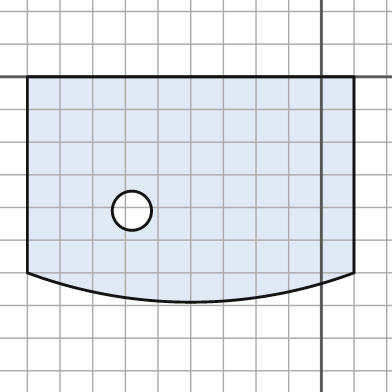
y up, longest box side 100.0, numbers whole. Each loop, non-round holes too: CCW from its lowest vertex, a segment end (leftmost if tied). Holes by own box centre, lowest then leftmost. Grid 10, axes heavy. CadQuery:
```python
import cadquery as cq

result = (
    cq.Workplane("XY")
    .moveTo(-90.0, -60.0)
    .threePointArc((-40.0, -69.0), (10.0, -60.0))
    .lineTo(10.0, 0.0)
    .lineTo(-90.0, 0.0)
    .close()
    .moveTo(-58.0, -41.0)
    .circle(6.0)
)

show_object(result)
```